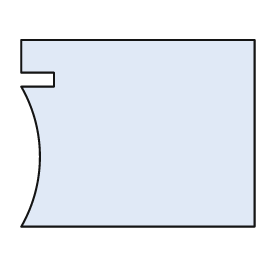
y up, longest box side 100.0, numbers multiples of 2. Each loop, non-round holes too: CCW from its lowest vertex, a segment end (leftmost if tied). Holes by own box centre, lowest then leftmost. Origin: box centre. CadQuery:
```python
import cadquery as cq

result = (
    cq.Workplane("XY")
    .moveTo(-50.0, -40.0)
    .lineTo(50.0, -40.0)
    .lineTo(50.0, 40.0)
    .lineTo(-50.0, 40.0)
    .lineTo(-50.0, 26.0)
    .lineTo(-36.0, 26.0)
    .lineTo(-36.0, 20.0)
    .lineTo(-50.0, 20.0)
    .threePointArc((-42.0, -10.0), (-50.0, -40.0))
    .close()
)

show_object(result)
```